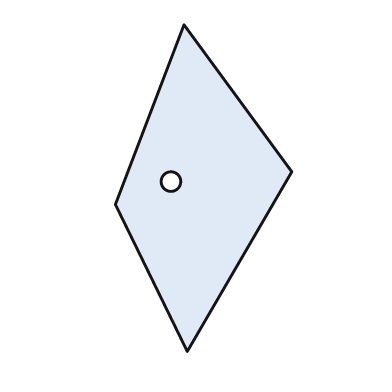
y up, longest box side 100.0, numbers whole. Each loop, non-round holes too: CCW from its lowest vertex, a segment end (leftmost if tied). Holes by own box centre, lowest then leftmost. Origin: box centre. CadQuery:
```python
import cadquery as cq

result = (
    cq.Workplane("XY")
    .moveTo(-5.0, -50.0)
    .lineTo(27.0, 5.0)
    .lineTo(-6.0, 50.0)
    .lineTo(-27.0, -5.0)
    .close()
    .moveTo(-10.0, 2.0)
    .circle(3.0)
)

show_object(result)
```